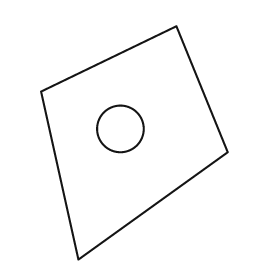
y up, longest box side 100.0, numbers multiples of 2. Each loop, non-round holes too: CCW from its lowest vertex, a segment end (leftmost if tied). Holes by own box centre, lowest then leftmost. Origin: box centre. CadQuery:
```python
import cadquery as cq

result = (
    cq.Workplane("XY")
    .moveTo(-24.0, -50.0)
    .lineTo(40.0, -4.0)
    .lineTo(18.0, 50.0)
    .lineTo(-40.0, 22.0)
    .close()
    .moveTo(-6.0, 6.0)
    .circle(10.0)
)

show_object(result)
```